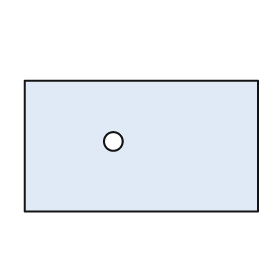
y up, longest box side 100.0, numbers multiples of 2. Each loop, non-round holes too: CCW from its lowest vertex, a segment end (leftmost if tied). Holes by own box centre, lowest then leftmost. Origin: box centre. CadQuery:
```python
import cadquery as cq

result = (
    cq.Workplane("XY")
    .moveTo(-50.0, -28.0)
    .lineTo(50.0, -28.0)
    .lineTo(50.0, 28.0)
    .lineTo(-50.0, 28.0)
    .close()
    .moveTo(-12.0, 2.0)
    .circle(4.0)
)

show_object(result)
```